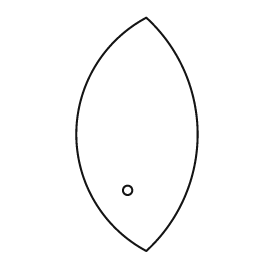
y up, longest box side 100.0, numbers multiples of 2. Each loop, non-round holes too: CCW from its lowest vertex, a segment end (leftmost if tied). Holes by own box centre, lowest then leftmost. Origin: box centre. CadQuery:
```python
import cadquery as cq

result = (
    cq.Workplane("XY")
    .moveTo(4.0, -50.0)
    .threePointArc((26.0, 0.0), (4.0, 50.0))
    .threePointArc((-26.0, 0.0), (4.0, -50.0))
    .close()
    .moveTo(-4.0, -24.0)
    .circle(2.0)
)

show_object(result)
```